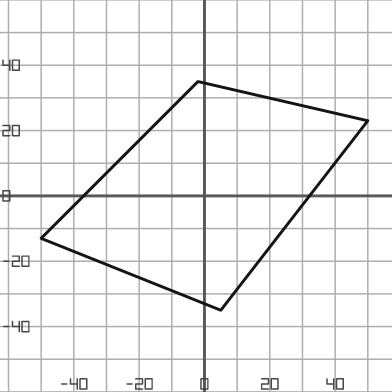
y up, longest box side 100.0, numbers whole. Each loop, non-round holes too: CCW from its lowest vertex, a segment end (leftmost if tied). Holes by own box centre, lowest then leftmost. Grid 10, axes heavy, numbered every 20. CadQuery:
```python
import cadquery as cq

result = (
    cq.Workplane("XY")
    .moveTo(5.0, -35.0)
    .lineTo(50.0, 23.0)
    .lineTo(-2.0, 35.0)
    .lineTo(-50.0, -13.0)
    .close()
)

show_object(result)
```